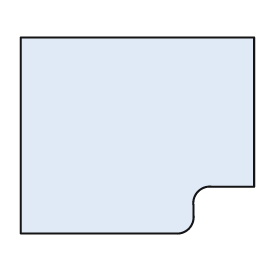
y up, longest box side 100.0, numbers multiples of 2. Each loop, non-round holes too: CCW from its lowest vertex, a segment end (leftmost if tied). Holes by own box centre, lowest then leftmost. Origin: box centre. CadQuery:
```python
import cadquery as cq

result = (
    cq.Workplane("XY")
    .moveTo(-50.0, -42.0)
    .lineTo(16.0, -42.0)
    .threePointArc((22.0, -40.0), (24.0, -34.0))
    .lineTo(24.0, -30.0)
    .threePointArc((26.0, -24.0), (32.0, -22.0))
    .lineTo(50.0, -22.0)
    .lineTo(50.0, 42.0)
    .lineTo(-50.0, 42.0)
    .close()
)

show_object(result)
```